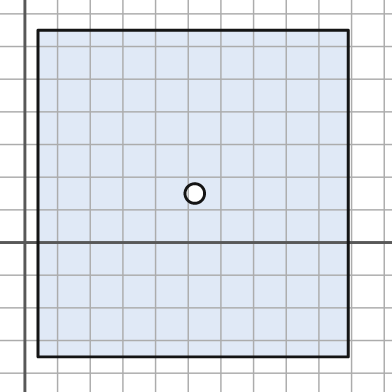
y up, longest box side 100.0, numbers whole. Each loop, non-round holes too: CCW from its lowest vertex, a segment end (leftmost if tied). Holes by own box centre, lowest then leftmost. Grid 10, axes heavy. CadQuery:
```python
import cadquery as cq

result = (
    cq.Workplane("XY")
    .moveTo(4.0, -35.0)
    .lineTo(99.0, -35.0)
    .lineTo(99.0, 65.0)
    .lineTo(4.0, 65.0)
    .close()
    .moveTo(52.0, 15.0)
    .circle(3.0)
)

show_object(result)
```